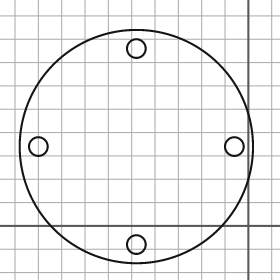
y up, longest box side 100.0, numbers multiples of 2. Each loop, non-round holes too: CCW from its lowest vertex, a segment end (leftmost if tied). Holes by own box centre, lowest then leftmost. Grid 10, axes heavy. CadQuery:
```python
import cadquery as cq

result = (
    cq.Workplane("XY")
    .moveTo(-48.0, 34.0)
    .circle(50.0)
    .moveTo(-48.0, -8.0)
    .circle(4.0)
    .moveTo(-90.0, 34.0)
    .circle(4.0)
    .moveTo(-6.0, 34.0)
    .circle(4.0)
    .moveTo(-48.0, 76.0)
    .circle(4.0)
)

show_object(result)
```